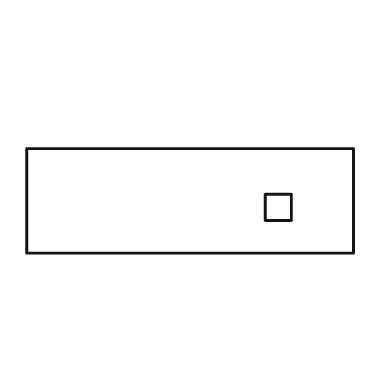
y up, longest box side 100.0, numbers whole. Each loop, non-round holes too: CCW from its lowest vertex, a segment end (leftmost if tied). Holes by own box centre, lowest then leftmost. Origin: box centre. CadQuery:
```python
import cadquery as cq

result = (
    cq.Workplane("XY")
    .moveTo(-50.0, -16.0)
    .lineTo(50.0, -16.0)
    .lineTo(50.0, 16.0)
    .lineTo(-50.0, 16.0)
    .close()
    .moveTo(23.0, -6.0)
    .lineTo(31.0, -6.0)
    .lineTo(31.0, 2.0)
    .lineTo(23.0, 2.0)
    .close()
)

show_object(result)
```